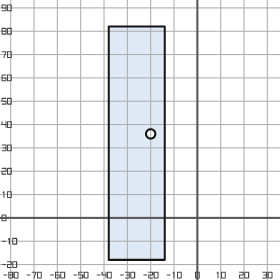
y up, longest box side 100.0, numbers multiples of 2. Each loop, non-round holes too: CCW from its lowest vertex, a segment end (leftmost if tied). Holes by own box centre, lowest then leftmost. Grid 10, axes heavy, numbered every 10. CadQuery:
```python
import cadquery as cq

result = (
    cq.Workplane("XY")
    .moveTo(-38.0, -18.0)
    .lineTo(-14.0, -18.0)
    .lineTo(-14.0, 82.0)
    .lineTo(-38.0, 82.0)
    .close()
    .moveTo(-20.0, 36.0)
    .circle(2.0)
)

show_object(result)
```